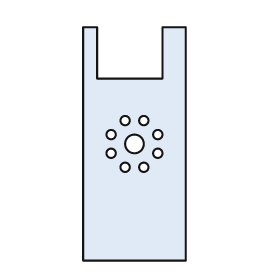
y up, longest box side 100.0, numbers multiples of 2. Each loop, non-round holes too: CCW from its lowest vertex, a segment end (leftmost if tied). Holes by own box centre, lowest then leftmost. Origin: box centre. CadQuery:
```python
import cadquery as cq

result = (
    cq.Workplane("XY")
    .moveTo(-22.0, -50.0)
    .lineTo(22.0, -50.0)
    .lineTo(22.0, 50.0)
    .lineTo(12.0, 50.0)
    .lineTo(12.0, 28.0)
    .lineTo(-16.0, 28.0)
    .lineTo(-16.0, 50.0)
    .lineTo(-22.0, 50.0)
    .close()
    .moveTo(-4.0, -10.0)
    .circle(2.0)
    .moveTo(4.0, -10.0)
    .circle(2.0)
    .moveTo(-10.0, -4.0)
    .circle(2.0)
    .moveTo(10.0, -4.0)
    .circle(2.0)
    .moveTo(0.0, 0.0)
    .circle(4.0)
    .moveTo(-10.0, 4.0)
    .circle(2.0)
    .moveTo(10.0, 4.0)
    .circle(2.0)
    .moveTo(-4.0, 10.0)
    .circle(2.0)
    .moveTo(4.0, 10.0)
    .circle(2.0)
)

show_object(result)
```